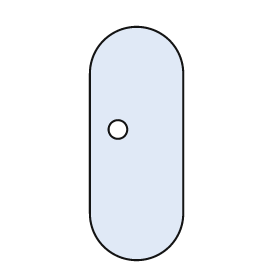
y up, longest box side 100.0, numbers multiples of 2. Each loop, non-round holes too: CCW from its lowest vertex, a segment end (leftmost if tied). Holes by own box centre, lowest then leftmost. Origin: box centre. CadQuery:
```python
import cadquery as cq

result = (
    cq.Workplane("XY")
    .moveTo(-20.0, -30.0)
    .threePointArc((0.0, -50.0), (20.0, -30.0))
    .lineTo(20.0, 30.0)
    .threePointArc((0.0, 50.0), (-20.0, 30.0))
    .close()
    .moveTo(-8.0, 6.0)
    .circle(4.0)
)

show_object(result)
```